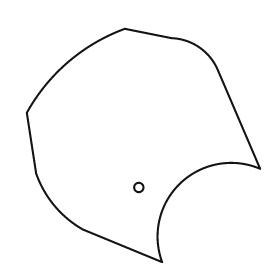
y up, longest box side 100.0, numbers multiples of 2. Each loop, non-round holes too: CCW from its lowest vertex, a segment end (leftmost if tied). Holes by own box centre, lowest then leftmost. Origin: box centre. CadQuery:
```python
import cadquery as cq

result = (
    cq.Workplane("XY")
    .moveTo(8.0, -50.0)
    .threePointArc((16.0, -16.0), (50.0, -10.0))
    .lineTo(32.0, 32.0)
    .threePointArc((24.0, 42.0), (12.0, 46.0))
    .lineTo(-8.0, 50.0)
    .threePointArc((-32.0, 36.0), (-50.0, 14.0))
    .lineTo(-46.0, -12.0)
    .threePointArc((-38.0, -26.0), (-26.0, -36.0))
    .close()
    .moveTo(-2.0, -18.0)
    .circle(2.0)
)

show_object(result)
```